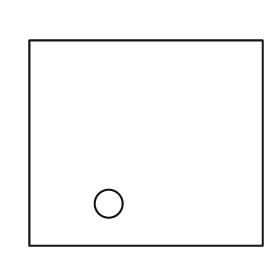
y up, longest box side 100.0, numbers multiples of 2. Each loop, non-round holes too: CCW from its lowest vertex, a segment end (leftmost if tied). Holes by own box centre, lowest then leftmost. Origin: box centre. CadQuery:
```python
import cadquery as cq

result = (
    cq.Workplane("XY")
    .moveTo(-50.0, -44.0)
    .lineTo(50.0, -44.0)
    .lineTo(50.0, 44.0)
    .lineTo(-50.0, 44.0)
    .close()
    .moveTo(-16.0, -26.0)
    .circle(6.0)
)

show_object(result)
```